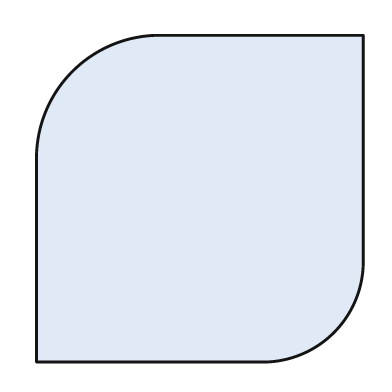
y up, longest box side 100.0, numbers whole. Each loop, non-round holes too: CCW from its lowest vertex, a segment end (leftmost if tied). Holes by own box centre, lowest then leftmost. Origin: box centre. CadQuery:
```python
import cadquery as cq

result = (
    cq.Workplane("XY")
    .moveTo(-50.0, -50.0)
    .lineTo(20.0, -50.0)
    .threePointArc((41.0, -41.0), (50.0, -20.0))
    .lineTo(50.0, 50.0)
    .lineTo(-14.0, 50.0)
    .threePointArc((-39.0, 39.0), (-50.0, 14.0))
    .close()
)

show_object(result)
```